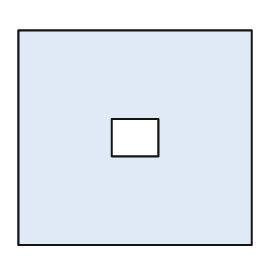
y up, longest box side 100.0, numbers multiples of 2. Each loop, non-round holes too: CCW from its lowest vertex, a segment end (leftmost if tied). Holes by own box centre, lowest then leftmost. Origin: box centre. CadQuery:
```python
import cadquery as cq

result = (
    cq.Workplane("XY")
    .moveTo(-50.0, -46.0)
    .lineTo(50.0, -46.0)
    .lineTo(50.0, 46.0)
    .lineTo(-50.0, 46.0)
    .close()
    .moveTo(-10.0, -8.0)
    .lineTo(10.0, -8.0)
    .lineTo(10.0, 8.0)
    .lineTo(-10.0, 8.0)
    .close()
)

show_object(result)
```